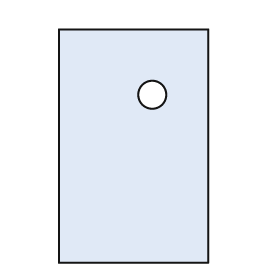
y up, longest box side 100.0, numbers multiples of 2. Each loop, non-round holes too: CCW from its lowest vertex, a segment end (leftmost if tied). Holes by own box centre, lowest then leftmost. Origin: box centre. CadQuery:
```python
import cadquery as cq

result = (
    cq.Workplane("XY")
    .moveTo(-32.0, -50.0)
    .lineTo(32.0, -50.0)
    .lineTo(32.0, 50.0)
    .lineTo(-32.0, 50.0)
    .close()
    .moveTo(8.0, 22.0)
    .circle(6.0)
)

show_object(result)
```